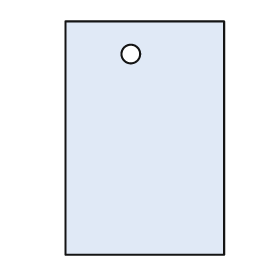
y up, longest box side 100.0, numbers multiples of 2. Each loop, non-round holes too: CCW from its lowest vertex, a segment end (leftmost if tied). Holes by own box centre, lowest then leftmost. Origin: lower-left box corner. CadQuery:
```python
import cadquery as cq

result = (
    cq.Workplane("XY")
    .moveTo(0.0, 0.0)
    .lineTo(68.0, 0.0)
    .lineTo(68.0, 100.0)
    .lineTo(0.0, 100.0)
    .close()
    .moveTo(28.0, 86.0)
    .circle(4.0)
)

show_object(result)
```